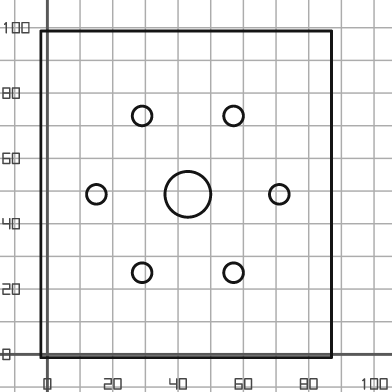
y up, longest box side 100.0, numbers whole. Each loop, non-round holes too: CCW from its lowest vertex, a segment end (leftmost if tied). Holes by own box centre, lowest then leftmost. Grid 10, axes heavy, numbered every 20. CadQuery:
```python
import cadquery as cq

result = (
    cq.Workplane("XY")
    .moveTo(-2.0, -1.0)
    .lineTo(87.0, -1.0)
    .lineTo(87.0, 99.0)
    .lineTo(-2.0, 99.0)
    .close()
    .moveTo(29.0, 25.0)
    .circle(3.0)
    .moveTo(57.0, 25.0)
    .circle(3.0)
    .moveTo(15.0, 49.0)
    .circle(3.0)
    .moveTo(43.0, 49.0)
    .circle(7.0)
    .moveTo(71.0, 49.0)
    .circle(3.0)
    .moveTo(29.0, 73.0)
    .circle(3.0)
    .moveTo(57.0, 73.0)
    .circle(3.0)
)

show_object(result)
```